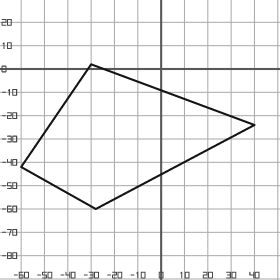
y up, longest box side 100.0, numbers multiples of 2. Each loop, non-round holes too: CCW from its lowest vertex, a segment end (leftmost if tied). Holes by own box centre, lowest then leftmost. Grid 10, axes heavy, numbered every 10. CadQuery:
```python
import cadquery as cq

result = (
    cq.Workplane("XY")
    .moveTo(-28.0, -60.0)
    .lineTo(40.0, -24.0)
    .lineTo(-30.0, 2.0)
    .lineTo(-60.0, -42.0)
    .close()
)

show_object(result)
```